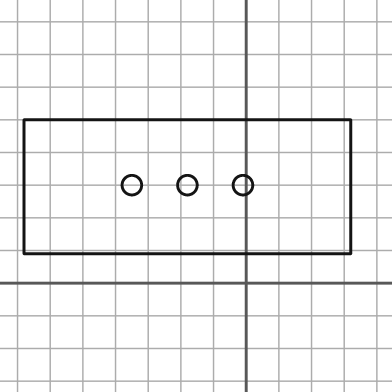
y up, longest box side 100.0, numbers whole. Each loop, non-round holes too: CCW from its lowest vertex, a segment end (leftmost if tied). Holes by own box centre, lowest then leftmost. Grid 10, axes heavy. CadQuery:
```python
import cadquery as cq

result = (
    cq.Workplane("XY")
    .moveTo(-68.0, 9.0)
    .lineTo(32.0, 9.0)
    .lineTo(32.0, 50.0)
    .lineTo(-68.0, 50.0)
    .close()
    .moveTo(-35.0, 30.0)
    .circle(3.0)
    .moveTo(-18.0, 30.0)
    .circle(3.0)
    .moveTo(-1.0, 30.0)
    .circle(3.0)
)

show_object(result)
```